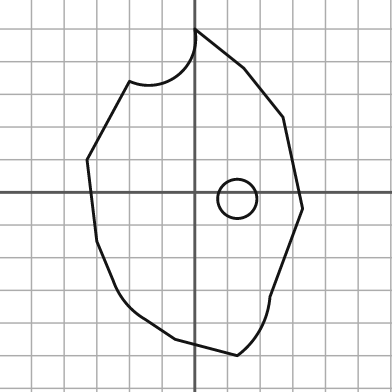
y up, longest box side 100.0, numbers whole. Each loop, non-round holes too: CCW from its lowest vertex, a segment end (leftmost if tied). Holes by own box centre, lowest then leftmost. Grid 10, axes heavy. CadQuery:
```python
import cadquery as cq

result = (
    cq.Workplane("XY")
    .moveTo(13.0, -50.0)
    .threePointArc((20.0, -42.0), (23.0, -32.0))
    .lineTo(33.0, -5.0)
    .lineTo(27.0, 23.0)
    .lineTo(15.0, 38.0)
    .lineTo(0.0, 50.0)
    .threePointArc((-5.0, 36.0), (-20.0, 34.0))
    .lineTo(-33.0, 10.0)
    .lineTo(-30.0, -15.0)
    .lineTo(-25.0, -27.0)
    .threePointArc((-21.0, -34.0), (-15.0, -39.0))
    .lineTo(-6.0, -45.0)
    .close()
    .moveTo(13.0, -2.0)
    .circle(6.0)
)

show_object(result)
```